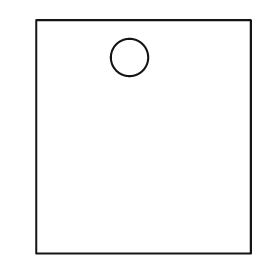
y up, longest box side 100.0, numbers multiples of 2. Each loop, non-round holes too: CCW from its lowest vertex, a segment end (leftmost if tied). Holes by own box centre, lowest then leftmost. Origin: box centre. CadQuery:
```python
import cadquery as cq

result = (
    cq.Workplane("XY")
    .moveTo(-46.0, -50.0)
    .lineTo(46.0, -50.0)
    .lineTo(46.0, 50.0)
    .lineTo(-46.0, 50.0)
    .close()
    .moveTo(-6.0, 34.0)
    .circle(8.0)
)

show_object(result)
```